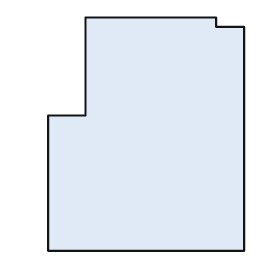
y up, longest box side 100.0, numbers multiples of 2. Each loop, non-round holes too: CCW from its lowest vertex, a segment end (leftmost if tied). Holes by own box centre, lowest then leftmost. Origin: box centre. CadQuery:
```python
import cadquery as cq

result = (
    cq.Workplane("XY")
    .moveTo(-42.0, -50.0)
    .lineTo(42.0, -50.0)
    .lineTo(42.0, 46.0)
    .lineTo(30.0, 46.0)
    .lineTo(30.0, 50.0)
    .lineTo(-26.0, 50.0)
    .lineTo(-26.0, 8.0)
    .lineTo(-42.0, 8.0)
    .close()
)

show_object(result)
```